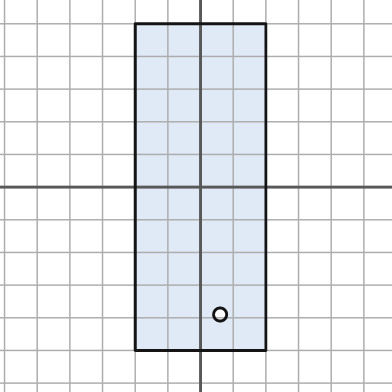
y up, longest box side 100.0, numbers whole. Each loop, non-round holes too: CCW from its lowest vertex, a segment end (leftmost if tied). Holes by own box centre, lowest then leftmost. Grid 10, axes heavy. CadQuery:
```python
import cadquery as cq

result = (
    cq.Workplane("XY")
    .moveTo(-20.0, -50.0)
    .lineTo(20.0, -50.0)
    .lineTo(20.0, 50.0)
    .lineTo(-20.0, 50.0)
    .close()
    .moveTo(6.0, -39.0)
    .circle(2.0)
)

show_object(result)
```